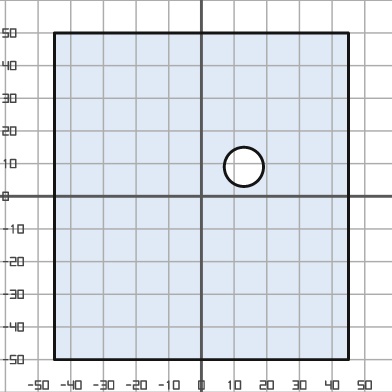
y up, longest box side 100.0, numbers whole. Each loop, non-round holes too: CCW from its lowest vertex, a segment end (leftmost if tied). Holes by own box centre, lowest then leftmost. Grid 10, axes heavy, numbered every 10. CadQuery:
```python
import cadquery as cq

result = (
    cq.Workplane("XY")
    .moveTo(-45.0, -50.0)
    .lineTo(45.0, -50.0)
    .lineTo(45.0, 50.0)
    .lineTo(-45.0, 50.0)
    .close()
    .moveTo(13.0, 9.0)
    .circle(6.0)
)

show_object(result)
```